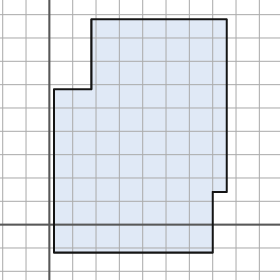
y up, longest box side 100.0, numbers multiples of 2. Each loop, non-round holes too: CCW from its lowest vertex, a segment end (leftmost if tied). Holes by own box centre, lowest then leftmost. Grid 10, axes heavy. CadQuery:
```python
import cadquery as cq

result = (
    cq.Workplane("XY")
    .moveTo(2.0, -12.0)
    .lineTo(70.0, -12.0)
    .lineTo(70.0, 14.0)
    .lineTo(76.0, 14.0)
    .lineTo(76.0, 88.0)
    .lineTo(18.0, 88.0)
    .lineTo(18.0, 58.0)
    .lineTo(2.0, 58.0)
    .close()
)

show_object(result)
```